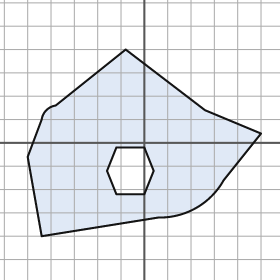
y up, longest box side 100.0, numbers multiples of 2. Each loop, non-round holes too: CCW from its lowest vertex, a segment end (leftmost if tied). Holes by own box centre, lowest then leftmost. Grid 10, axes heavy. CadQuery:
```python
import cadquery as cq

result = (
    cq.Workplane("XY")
    .moveTo(-44.0, -40.0)
    .lineTo(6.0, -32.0)
    .threePointArc((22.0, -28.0), (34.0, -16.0))
    .lineTo(50.0, 4.0)
    .lineTo(26.0, 14.0)
    .lineTo(-8.0, 40.0)
    .lineTo(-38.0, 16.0)
    .threePointArc((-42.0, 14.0), (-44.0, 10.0))
    .lineTo(-50.0, -6.0)
    .close()
    .moveTo(-12.0, -22.0)
    .lineTo(0.0, -22.0)
    .lineTo(4.0, -12.0)
    .lineTo(0.0, -2.0)
    .lineTo(-12.0, -2.0)
    .lineTo(-16.0, -12.0)
    .close()
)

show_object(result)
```